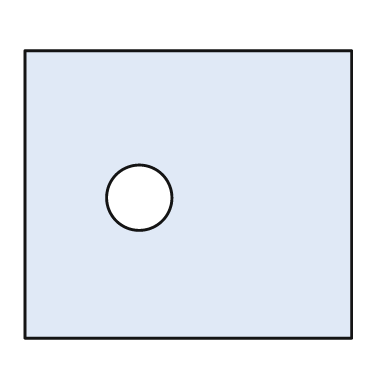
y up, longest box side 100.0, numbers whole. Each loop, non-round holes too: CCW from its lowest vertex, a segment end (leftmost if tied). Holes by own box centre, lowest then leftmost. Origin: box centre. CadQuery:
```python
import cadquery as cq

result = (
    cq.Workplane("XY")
    .moveTo(-50.0, -44.0)
    .lineTo(50.0, -44.0)
    .lineTo(50.0, 44.0)
    .lineTo(-50.0, 44.0)
    .close()
    .moveTo(-15.0, -1.0)
    .circle(10.0)
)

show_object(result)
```